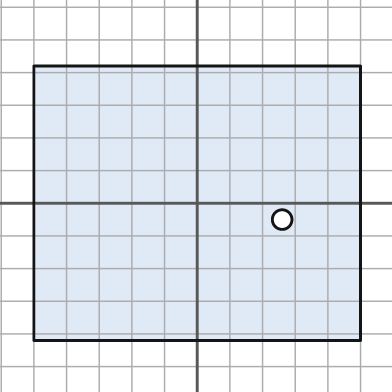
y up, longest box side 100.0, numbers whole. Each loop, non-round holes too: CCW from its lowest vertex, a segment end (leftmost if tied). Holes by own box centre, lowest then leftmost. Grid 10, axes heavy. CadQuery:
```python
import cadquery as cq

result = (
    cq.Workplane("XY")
    .moveTo(-50.0, -42.0)
    .lineTo(50.0, -42.0)
    .lineTo(50.0, 42.0)
    .lineTo(-50.0, 42.0)
    .close()
    .moveTo(26.0, -5.0)
    .circle(3.0)
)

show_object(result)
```